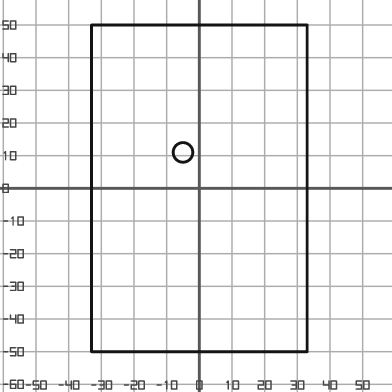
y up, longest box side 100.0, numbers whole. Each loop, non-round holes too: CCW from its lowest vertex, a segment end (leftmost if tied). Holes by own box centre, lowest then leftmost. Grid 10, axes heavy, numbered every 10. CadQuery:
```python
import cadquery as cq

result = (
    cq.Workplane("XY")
    .moveTo(-33.0, -50.0)
    .lineTo(33.0, -50.0)
    .lineTo(33.0, 50.0)
    .lineTo(-33.0, 50.0)
    .close()
    .moveTo(-5.0, 11.0)
    .circle(3.0)
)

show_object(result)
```